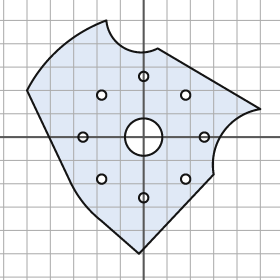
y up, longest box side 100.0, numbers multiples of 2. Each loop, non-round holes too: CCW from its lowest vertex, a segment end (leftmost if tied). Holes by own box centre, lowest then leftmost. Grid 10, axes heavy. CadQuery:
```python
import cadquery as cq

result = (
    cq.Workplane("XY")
    .moveTo(-2.0, -50.0)
    .lineTo(30.0, -16.0)
    .threePointArc((34.0, 2.0), (50.0, 12.0))
    .lineTo(6.0, 38.0)
    .threePointArc((-8.0, 38.0), (-16.0, 50.0))
    .threePointArc((-36.0, 38.0), (-50.0, 20.0))
    .lineTo(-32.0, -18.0)
    .threePointArc((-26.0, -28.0), (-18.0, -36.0))
    .close()
    .moveTo(0.0, -26.0)
    .circle(2.0)
    .moveTo(-18.0, -18.0)
    .circle(2.0)
    .moveTo(18.0, -18.0)
    .circle(2.0)
    .moveTo(-26.0, 0.0)
    .circle(2.0)
    .moveTo(0.0, 0.0)
    .circle(8.0)
    .moveTo(26.0, 0.0)
    .circle(2.0)
    .moveTo(-18.0, 18.0)
    .circle(2.0)
    .moveTo(18.0, 18.0)
    .circle(2.0)
    .moveTo(0.0, 26.0)
    .circle(2.0)
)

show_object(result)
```